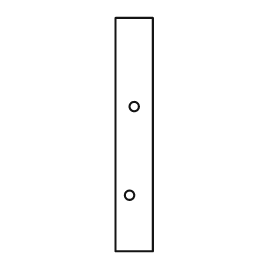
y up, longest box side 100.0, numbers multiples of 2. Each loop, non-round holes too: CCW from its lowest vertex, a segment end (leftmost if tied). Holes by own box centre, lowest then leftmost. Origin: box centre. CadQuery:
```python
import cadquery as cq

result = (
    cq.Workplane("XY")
    .moveTo(-8.0, -50.0)
    .lineTo(8.0, -50.0)
    .lineTo(8.0, 50.0)
    .lineTo(-8.0, 50.0)
    .close()
    .moveTo(-2.0, -26.0)
    .circle(2.0)
    .moveTo(0.0, 12.0)
    .circle(2.0)
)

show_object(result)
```